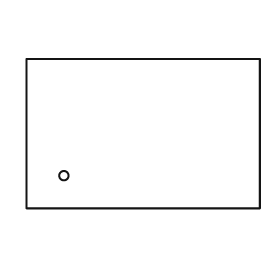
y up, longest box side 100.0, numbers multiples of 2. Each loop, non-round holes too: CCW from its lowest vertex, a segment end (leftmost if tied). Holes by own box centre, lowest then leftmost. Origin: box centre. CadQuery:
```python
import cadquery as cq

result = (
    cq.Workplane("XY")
    .moveTo(-50.0, -32.0)
    .lineTo(50.0, -32.0)
    .lineTo(50.0, 32.0)
    .lineTo(-50.0, 32.0)
    .close()
    .moveTo(-34.0, -18.0)
    .circle(2.0)
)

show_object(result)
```